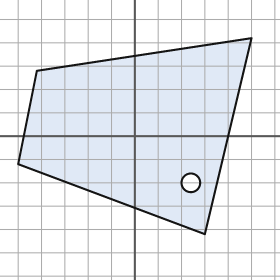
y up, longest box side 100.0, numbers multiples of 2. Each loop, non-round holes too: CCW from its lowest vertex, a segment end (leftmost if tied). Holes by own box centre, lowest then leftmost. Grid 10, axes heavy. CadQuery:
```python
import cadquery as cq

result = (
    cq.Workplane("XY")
    .moveTo(30.0, -42.0)
    .lineTo(50.0, 42.0)
    .lineTo(-42.0, 28.0)
    .lineTo(-50.0, -12.0)
    .close()
    .moveTo(24.0, -20.0)
    .circle(4.0)
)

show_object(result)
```